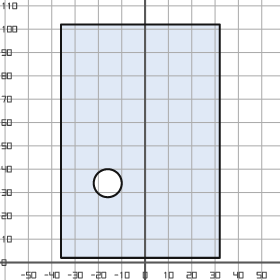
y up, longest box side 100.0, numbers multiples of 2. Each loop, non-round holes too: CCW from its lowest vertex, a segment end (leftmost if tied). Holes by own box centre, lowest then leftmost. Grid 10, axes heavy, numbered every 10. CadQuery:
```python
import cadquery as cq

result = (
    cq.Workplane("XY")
    .moveTo(-36.0, 2.0)
    .lineTo(32.0, 2.0)
    .lineTo(32.0, 102.0)
    .lineTo(-36.0, 102.0)
    .close()
    .moveTo(-16.0, 34.0)
    .circle(6.0)
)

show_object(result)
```